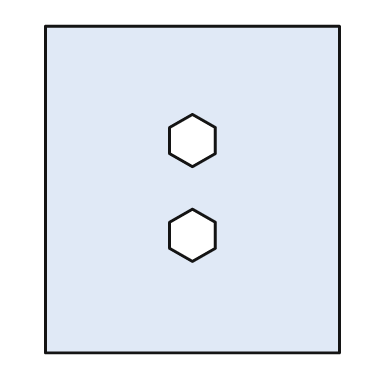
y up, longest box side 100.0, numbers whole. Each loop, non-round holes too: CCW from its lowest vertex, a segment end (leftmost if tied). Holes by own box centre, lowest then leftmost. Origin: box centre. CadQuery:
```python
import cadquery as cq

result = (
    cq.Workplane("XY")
    .moveTo(-45.0, -50.0)
    .lineTo(45.0, -50.0)
    .lineTo(45.0, 50.0)
    .lineTo(-45.0, 50.0)
    .close()
    .moveTo(0.0, -22.0)
    .lineTo(7.0, -18.0)
    .lineTo(7.0, -10.0)
    .lineTo(0.0, -6.0)
    .lineTo(-7.0, -10.0)
    .lineTo(-7.0, -18.0)
    .close()
    .moveTo(0.0, 7.0)
    .lineTo(7.0, 11.0)
    .lineTo(7.0, 19.0)
    .lineTo(0.0, 23.0)
    .lineTo(-7.0, 19.0)
    .lineTo(-7.0, 11.0)
    .close()
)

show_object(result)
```